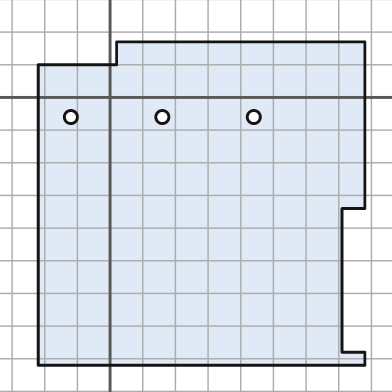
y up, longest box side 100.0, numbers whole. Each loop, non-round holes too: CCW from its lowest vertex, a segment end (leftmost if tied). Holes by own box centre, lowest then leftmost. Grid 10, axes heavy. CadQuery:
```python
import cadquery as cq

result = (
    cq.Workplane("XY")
    .moveTo(-22.0, -82.0)
    .lineTo(78.0, -82.0)
    .lineTo(78.0, -78.0)
    .lineTo(71.0, -78.0)
    .lineTo(71.0, -34.0)
    .lineTo(78.0, -34.0)
    .lineTo(78.0, 17.0)
    .lineTo(2.0, 17.0)
    .lineTo(2.0, 10.0)
    .lineTo(-22.0, 10.0)
    .close()
    .moveTo(-12.0, -6.0)
    .circle(2.0)
    .moveTo(16.0, -6.0)
    .circle(2.0)
    .moveTo(44.0, -6.0)
    .circle(2.0)
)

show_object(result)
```